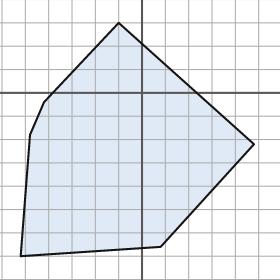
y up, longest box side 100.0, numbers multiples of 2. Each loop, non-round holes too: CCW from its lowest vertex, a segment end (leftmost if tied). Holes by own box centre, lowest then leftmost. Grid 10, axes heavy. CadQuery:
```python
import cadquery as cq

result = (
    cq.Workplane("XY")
    .moveTo(-52.0, -70.0)
    .lineTo(8.0, -66.0)
    .lineTo(48.0, -22.0)
    .lineTo(-10.0, 30.0)
    .lineTo(-42.0, -4.0)
    .lineTo(-48.0, -18.0)
    .close()
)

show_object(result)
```